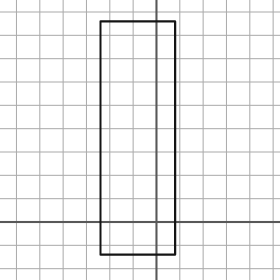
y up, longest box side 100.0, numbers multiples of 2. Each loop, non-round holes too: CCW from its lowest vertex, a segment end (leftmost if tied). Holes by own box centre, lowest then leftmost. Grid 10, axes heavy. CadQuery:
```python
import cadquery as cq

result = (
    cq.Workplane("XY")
    .moveTo(-24.0, -14.0)
    .lineTo(8.0, -14.0)
    .lineTo(8.0, 86.0)
    .lineTo(-24.0, 86.0)
    .close()
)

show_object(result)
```